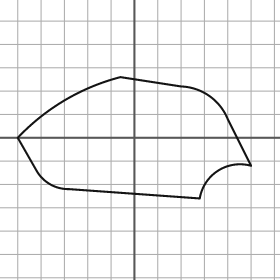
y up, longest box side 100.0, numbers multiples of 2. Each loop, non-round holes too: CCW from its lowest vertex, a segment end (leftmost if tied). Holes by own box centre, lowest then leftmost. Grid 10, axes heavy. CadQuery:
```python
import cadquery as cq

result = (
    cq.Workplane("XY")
    .moveTo(28.0, -26.0)
    .threePointArc((36.0, -14.0), (50.0, -12.0))
    .lineTo(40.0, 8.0)
    .threePointArc((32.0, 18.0), (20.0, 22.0))
    .lineTo(-6.0, 26.0)
    .threePointArc((-30.0, 16.0), (-50.0, 0.0))
    .lineTo(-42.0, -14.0)
    .threePointArc((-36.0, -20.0), (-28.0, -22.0))
    .close()
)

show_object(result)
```